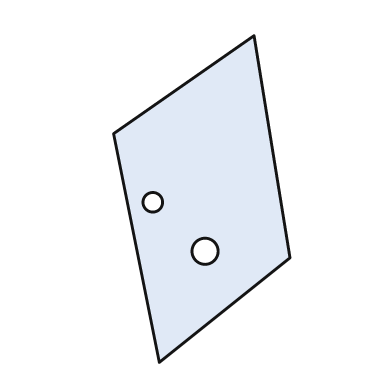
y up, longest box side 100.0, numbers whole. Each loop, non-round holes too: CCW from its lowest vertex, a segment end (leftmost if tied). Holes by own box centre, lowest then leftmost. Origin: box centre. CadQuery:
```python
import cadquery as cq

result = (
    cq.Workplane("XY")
    .moveTo(-13.0, -50.0)
    .lineTo(27.0, -18.0)
    .lineTo(16.0, 50.0)
    .lineTo(-27.0, 20.0)
    .close()
    .moveTo(1.0, -16.0)
    .circle(4.0)
    .moveTo(-15.0, -1.0)
    .circle(3.0)
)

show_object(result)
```